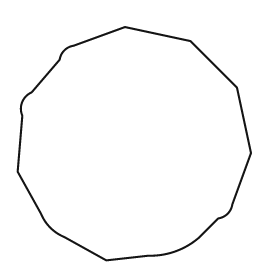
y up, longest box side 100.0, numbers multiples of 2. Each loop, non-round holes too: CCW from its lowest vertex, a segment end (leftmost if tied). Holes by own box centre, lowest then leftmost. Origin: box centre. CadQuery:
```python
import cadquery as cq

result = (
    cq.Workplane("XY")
    .moveTo(-12.0, -50.0)
    .lineTo(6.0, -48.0)
    .threePointArc((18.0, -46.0), (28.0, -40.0))
    .lineTo(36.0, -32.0)
    .threePointArc((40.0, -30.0), (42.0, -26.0))
    .lineTo(50.0, -4.0)
    .lineTo(44.0, 24.0)
    .lineTo(24.0, 44.0)
    .lineTo(-4.0, 50.0)
    .lineTo(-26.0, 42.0)
    .threePointArc((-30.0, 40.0), (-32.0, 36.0))
    .lineTo(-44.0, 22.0)
    .threePointArc((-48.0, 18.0), (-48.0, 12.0))
    .lineTo(-50.0, -12.0)
    .lineTo(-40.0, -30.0)
    .threePointArc((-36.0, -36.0), (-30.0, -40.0))
    .close()
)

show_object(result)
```